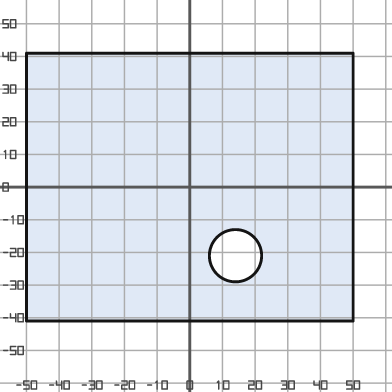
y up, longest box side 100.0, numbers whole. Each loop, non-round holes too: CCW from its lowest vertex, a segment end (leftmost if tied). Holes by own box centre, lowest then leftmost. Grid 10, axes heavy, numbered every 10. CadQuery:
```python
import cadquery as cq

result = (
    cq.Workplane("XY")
    .moveTo(-50.0, -41.0)
    .lineTo(50.0, -41.0)
    .lineTo(50.0, 41.0)
    .lineTo(-50.0, 41.0)
    .close()
    .moveTo(14.0, -21.0)
    .circle(8.0)
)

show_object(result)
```